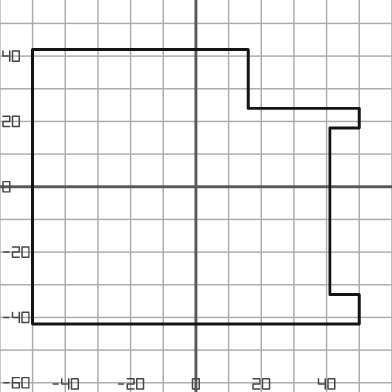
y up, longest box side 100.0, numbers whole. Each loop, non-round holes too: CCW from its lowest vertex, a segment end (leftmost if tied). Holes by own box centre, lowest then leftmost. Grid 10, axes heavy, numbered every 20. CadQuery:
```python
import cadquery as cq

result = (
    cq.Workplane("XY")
    .moveTo(-50.0, -42.0)
    .lineTo(50.0, -42.0)
    .lineTo(50.0, -33.0)
    .lineTo(41.0, -33.0)
    .lineTo(41.0, 18.0)
    .lineTo(50.0, 18.0)
    .lineTo(50.0, 24.0)
    .lineTo(16.0, 24.0)
    .lineTo(16.0, 42.0)
    .lineTo(-50.0, 42.0)
    .close()
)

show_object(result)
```